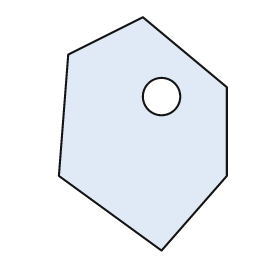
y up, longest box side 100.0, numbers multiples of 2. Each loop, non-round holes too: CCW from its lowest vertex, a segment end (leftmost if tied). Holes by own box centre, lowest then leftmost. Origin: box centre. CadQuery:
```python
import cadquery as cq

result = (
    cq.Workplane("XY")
    .moveTo(8.0, -50.0)
    .lineTo(36.0, -18.0)
    .lineTo(36.0, 20.0)
    .lineTo(0.0, 50.0)
    .lineTo(-32.0, 34.0)
    .lineTo(-36.0, -18.0)
    .close()
    .moveTo(8.0, 16.0)
    .circle(8.0)
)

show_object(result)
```